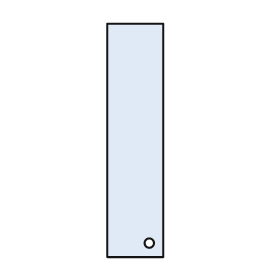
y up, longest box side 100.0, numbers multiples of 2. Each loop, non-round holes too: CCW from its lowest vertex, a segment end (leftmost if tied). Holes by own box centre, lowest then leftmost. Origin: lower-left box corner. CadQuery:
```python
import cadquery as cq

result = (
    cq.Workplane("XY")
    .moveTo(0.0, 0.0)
    .lineTo(24.0, 0.0)
    .lineTo(24.0, 100.0)
    .lineTo(0.0, 100.0)
    .close()
    .moveTo(18.0, 6.0)
    .circle(2.0)
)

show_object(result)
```